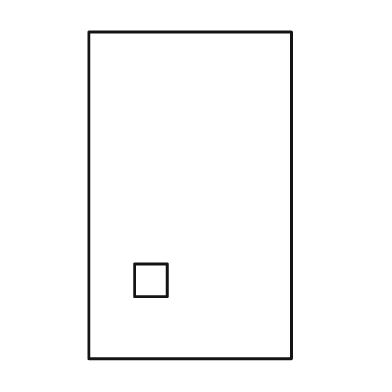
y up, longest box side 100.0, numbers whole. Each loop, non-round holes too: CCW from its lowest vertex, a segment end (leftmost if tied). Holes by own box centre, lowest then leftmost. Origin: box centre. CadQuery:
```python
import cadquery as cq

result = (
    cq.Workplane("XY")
    .moveTo(-31.0, -50.0)
    .lineTo(31.0, -50.0)
    .lineTo(31.0, 50.0)
    .lineTo(-31.0, 50.0)
    .close()
    .moveTo(-17.0, -31.0)
    .lineTo(-7.0, -31.0)
    .lineTo(-7.0, -21.0)
    .lineTo(-17.0, -21.0)
    .close()
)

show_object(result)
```